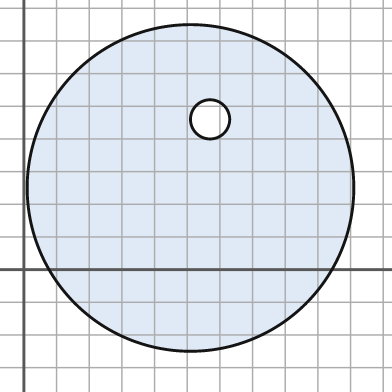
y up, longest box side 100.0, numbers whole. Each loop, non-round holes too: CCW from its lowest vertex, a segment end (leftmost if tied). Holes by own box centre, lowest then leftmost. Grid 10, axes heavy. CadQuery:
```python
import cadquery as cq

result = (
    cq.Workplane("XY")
    .moveTo(51.0, 25.0)
    .circle(50.0)
    .moveTo(57.0, 46.0)
    .circle(6.0)
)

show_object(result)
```